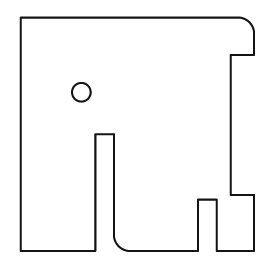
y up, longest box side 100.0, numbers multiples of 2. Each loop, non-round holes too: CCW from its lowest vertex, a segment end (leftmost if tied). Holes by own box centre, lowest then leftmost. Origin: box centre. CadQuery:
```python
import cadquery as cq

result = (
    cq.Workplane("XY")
    .moveTo(-50.0, -50.0)
    .lineTo(-18.0, -50.0)
    .lineTo(-18.0, 0.0)
    .lineTo(-10.0, 0.0)
    .lineTo(-10.0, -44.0)
    .threePointArc((-8.0, -48.0), (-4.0, -50.0))
    .lineTo(26.0, -50.0)
    .lineTo(26.0, -28.0)
    .lineTo(34.0, -28.0)
    .lineTo(34.0, -50.0)
    .lineTo(50.0, -50.0)
    .lineTo(50.0, -26.0)
    .lineTo(40.0, -26.0)
    .lineTo(40.0, 34.0)
    .lineTo(50.0, 34.0)
    .lineTo(50.0, 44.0)
    .threePointArc((48.0, 48.0), (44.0, 50.0))
    .lineTo(-50.0, 50.0)
    .close()
    .moveTo(-24.0, 18.0)
    .circle(4.0)
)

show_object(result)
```